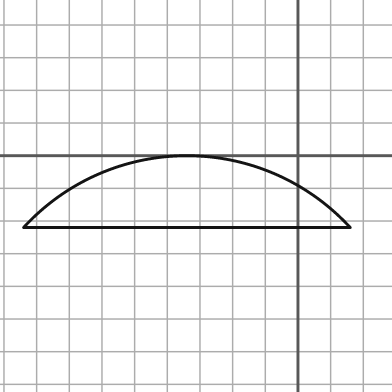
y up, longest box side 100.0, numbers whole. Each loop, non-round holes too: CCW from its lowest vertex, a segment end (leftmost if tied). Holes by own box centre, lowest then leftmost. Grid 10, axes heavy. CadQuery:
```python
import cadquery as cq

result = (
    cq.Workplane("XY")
    .moveTo(-84.0, -22.0)
    .lineTo(16.0, -22.0)
    .threePointArc((-34.0, 0.0), (-84.0, -22.0))
    .close()
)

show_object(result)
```